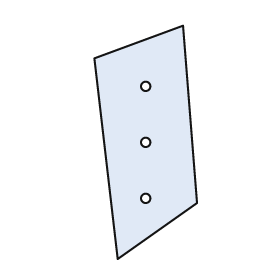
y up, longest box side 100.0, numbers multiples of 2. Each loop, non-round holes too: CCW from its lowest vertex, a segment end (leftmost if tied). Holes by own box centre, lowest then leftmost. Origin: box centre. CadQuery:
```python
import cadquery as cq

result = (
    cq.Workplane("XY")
    .moveTo(-12.0, -50.0)
    .lineTo(22.0, -26.0)
    .lineTo(16.0, 50.0)
    .lineTo(-22.0, 36.0)
    .close()
    .moveTo(0.0, -24.0)
    .circle(2.0)
    .moveTo(0.0, 0.0)
    .circle(2.0)
    .moveTo(0.0, 24.0)
    .circle(2.0)
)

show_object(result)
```